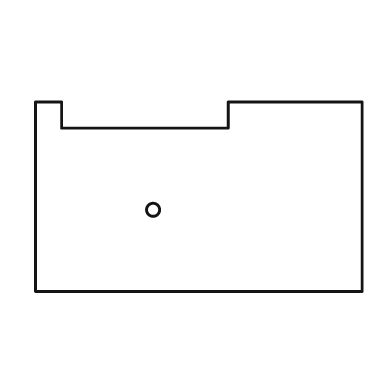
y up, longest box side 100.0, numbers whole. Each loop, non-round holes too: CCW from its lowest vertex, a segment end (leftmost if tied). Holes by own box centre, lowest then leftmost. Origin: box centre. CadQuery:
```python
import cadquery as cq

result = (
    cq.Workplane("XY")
    .moveTo(-50.0, -29.0)
    .lineTo(50.0, -29.0)
    .lineTo(50.0, 29.0)
    .lineTo(9.0, 29.0)
    .lineTo(9.0, 21.0)
    .lineTo(-42.0, 21.0)
    .lineTo(-42.0, 29.0)
    .lineTo(-50.0, 29.0)
    .close()
    .moveTo(-14.0, -4.0)
    .circle(2.0)
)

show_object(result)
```